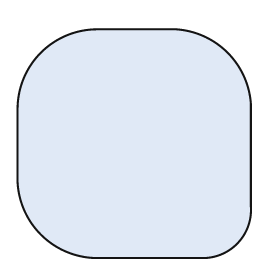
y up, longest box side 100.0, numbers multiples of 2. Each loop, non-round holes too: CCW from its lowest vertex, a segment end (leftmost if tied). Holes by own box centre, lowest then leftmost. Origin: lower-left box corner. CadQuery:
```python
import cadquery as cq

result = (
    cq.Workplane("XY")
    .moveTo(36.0, 0.0)
    .lineTo(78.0, 0.0)
    .threePointArc((94.0, 6.0), (100.0, 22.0))
    .lineTo(100.0, 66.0)
    .threePointArc((90.0, 88.0), (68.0, 98.0))
    .lineTo(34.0, 98.0)
    .threePointArc((10.0, 88.0), (0.0, 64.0))
    .lineTo(0.0, 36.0)
    .threePointArc((10.0, 10.0), (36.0, 0.0))
    .close()
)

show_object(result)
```